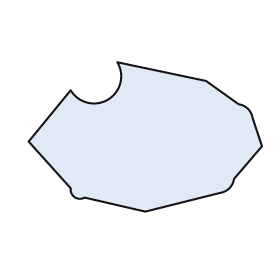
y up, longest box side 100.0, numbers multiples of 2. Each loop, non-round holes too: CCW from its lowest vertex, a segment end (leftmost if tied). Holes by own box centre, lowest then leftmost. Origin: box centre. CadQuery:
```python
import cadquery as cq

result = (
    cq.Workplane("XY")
    .moveTo(0.0, -32.0)
    .lineTo(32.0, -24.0)
    .threePointArc((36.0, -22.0), (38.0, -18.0))
    .lineTo(50.0, -4.0)
    .lineTo(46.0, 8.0)
    .threePointArc((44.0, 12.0), (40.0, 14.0))
    .lineTo(26.0, 24.0)
    .lineTo(-12.0, 32.0)
    .threePointArc((-16.0, 16.0), (-32.0, 20.0))
    .lineTo(-50.0, -2.0)
    .lineTo(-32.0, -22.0)
    .threePointArc((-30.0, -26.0), (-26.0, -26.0))
    .close()
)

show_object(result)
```